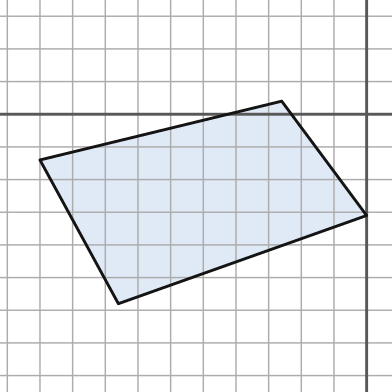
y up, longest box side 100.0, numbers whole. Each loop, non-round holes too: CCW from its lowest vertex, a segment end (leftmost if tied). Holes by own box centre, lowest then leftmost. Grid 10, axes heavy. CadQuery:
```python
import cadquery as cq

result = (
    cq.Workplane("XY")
    .moveTo(-76.0, -58.0)
    .lineTo(0.0, -31.0)
    .lineTo(-26.0, 4.0)
    .lineTo(-100.0, -14.0)
    .close()
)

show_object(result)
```